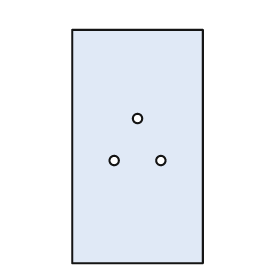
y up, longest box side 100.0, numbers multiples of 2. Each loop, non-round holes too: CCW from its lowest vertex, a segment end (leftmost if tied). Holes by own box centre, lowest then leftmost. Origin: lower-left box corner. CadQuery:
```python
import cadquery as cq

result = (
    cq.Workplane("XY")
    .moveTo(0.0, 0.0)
    .lineTo(56.0, 0.0)
    .lineTo(56.0, 100.0)
    .lineTo(0.0, 100.0)
    .close()
    .moveTo(18.0, 44.0)
    .circle(2.0)
    .moveTo(38.0, 44.0)
    .circle(2.0)
    .moveTo(28.0, 62.0)
    .circle(2.0)
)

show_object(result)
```